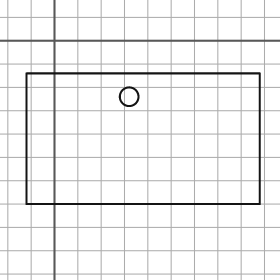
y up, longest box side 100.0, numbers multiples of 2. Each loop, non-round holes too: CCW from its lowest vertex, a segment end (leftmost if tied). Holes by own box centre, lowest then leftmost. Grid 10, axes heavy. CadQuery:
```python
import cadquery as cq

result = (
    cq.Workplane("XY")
    .moveTo(-12.0, -70.0)
    .lineTo(88.0, -70.0)
    .lineTo(88.0, -14.0)
    .lineTo(-12.0, -14.0)
    .close()
    .moveTo(32.0, -24.0)
    .circle(4.0)
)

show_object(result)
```